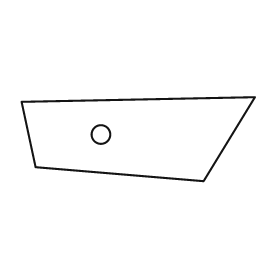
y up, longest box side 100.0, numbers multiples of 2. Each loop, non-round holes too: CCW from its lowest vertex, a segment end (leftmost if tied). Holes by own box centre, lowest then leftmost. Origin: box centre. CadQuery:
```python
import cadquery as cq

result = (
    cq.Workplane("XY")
    .moveTo(28.0, -18.0)
    .lineTo(50.0, 18.0)
    .lineTo(-50.0, 16.0)
    .lineTo(-44.0, -12.0)
    .close()
    .moveTo(-16.0, 2.0)
    .circle(4.0)
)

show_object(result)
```